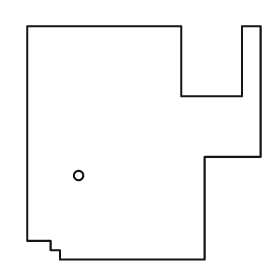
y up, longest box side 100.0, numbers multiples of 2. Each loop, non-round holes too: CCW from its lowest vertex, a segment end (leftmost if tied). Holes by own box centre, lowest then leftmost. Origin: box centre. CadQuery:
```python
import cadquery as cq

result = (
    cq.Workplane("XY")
    .moveTo(-36.0, -50.0)
    .lineTo(26.0, -50.0)
    .lineTo(26.0, -6.0)
    .lineTo(50.0, -6.0)
    .lineTo(50.0, 50.0)
    .lineTo(42.0, 50.0)
    .lineTo(42.0, 20.0)
    .lineTo(16.0, 20.0)
    .lineTo(16.0, 50.0)
    .lineTo(-50.0, 50.0)
    .lineTo(-50.0, -42.0)
    .lineTo(-40.0, -42.0)
    .lineTo(-40.0, -46.0)
    .lineTo(-36.0, -46.0)
    .close()
    .moveTo(-28.0, -14.0)
    .circle(2.0)
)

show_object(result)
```